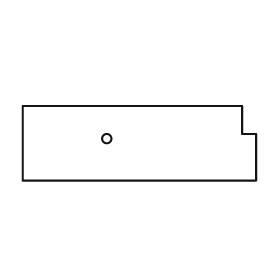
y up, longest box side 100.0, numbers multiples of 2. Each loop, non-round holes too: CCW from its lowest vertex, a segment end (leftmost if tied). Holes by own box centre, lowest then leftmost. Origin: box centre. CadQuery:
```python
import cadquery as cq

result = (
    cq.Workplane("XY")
    .moveTo(-50.0, -16.0)
    .lineTo(50.0, -16.0)
    .lineTo(50.0, 4.0)
    .lineTo(44.0, 4.0)
    .lineTo(44.0, 16.0)
    .lineTo(-50.0, 16.0)
    .close()
    .moveTo(-14.0, 2.0)
    .circle(2.0)
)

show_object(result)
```